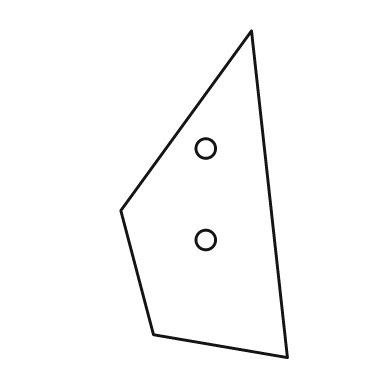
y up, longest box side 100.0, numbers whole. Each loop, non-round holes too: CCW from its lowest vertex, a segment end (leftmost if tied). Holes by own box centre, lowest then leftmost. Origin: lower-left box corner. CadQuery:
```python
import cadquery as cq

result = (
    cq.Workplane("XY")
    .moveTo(51.0, 0.0)
    .lineTo(40.0, 100.0)
    .lineTo(0.0, 45.0)
    .lineTo(10.0, 7.0)
    .close()
    .moveTo(26.0, 36.0)
    .circle(3.0)
    .moveTo(26.0, 64.0)
    .circle(3.0)
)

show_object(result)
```